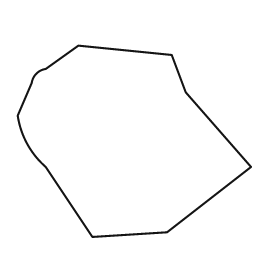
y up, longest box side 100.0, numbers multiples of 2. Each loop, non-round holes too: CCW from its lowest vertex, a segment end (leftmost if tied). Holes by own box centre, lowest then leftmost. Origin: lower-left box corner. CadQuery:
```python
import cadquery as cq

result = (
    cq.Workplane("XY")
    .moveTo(32.0, 0.0)
    .lineTo(64.0, 2.0)
    .lineTo(100.0, 30.0)
    .lineTo(72.0, 62.0)
    .lineTo(66.0, 78.0)
    .lineTo(26.0, 82.0)
    .lineTo(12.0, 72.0)
    .threePointArc((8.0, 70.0), (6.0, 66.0))
    .lineTo(0.0, 52.0)
    .threePointArc((4.0, 40.0), (12.0, 30.0))
    .close()
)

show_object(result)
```